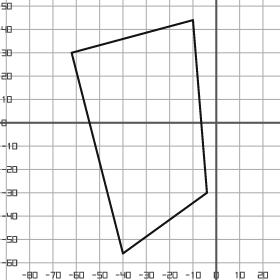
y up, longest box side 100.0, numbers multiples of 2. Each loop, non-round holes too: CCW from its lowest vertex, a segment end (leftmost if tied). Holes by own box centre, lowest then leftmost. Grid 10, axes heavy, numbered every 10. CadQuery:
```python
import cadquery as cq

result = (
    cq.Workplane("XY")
    .moveTo(-40.0, -56.0)
    .lineTo(-4.0, -30.0)
    .lineTo(-10.0, 44.0)
    .lineTo(-62.0, 30.0)
    .close()
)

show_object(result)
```